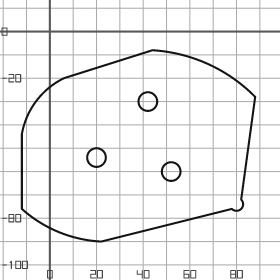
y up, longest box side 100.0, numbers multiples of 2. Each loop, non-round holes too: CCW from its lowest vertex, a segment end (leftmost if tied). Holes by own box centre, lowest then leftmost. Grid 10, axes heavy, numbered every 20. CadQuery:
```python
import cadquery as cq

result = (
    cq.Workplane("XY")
    .moveTo(22.0, -90.0)
    .lineTo(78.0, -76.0)
    .threePointArc((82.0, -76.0), (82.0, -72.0))
    .lineTo(88.0, -28.0)
    .threePointArc((68.0, -14.0), (44.0, -8.0))
    .lineTo(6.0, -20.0)
    .threePointArc((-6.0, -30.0), (-12.0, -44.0))
    .lineTo(-12.0, -76.0)
    .threePointArc((4.0, -86.0), (22.0, -90.0))
    .close()
    .moveTo(52.0, -60.0)
    .circle(4.0)
    .moveTo(20.0, -54.0)
    .circle(4.0)
    .moveTo(42.0, -30.0)
    .circle(4.0)
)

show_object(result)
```